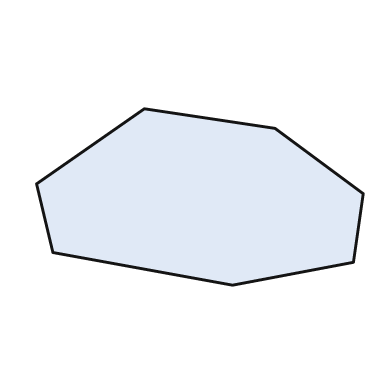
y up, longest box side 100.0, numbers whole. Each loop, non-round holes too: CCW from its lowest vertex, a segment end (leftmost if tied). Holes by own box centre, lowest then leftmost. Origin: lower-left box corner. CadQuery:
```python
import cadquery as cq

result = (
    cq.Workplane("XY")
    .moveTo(60.0, 0.0)
    .lineTo(97.0, 7.0)
    .lineTo(100.0, 28.0)
    .lineTo(73.0, 48.0)
    .lineTo(33.0, 54.0)
    .lineTo(0.0, 31.0)
    .lineTo(5.0, 10.0)
    .close()
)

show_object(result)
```